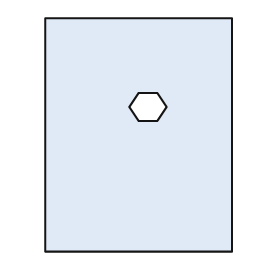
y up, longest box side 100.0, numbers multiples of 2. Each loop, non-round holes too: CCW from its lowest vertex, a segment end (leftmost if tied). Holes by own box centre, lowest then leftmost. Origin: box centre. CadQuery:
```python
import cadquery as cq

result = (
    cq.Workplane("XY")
    .moveTo(-40.0, -50.0)
    .lineTo(40.0, -50.0)
    .lineTo(40.0, 50.0)
    .lineTo(-40.0, 50.0)
    .close()
    .moveTo(0.0, 6.0)
    .lineTo(8.0, 6.0)
    .lineTo(12.0, 12.0)
    .lineTo(8.0, 18.0)
    .lineTo(0.0, 18.0)
    .lineTo(-4.0, 12.0)
    .close()
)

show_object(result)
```